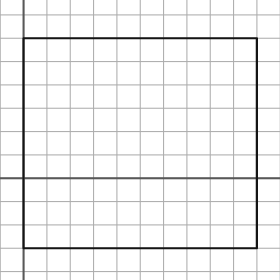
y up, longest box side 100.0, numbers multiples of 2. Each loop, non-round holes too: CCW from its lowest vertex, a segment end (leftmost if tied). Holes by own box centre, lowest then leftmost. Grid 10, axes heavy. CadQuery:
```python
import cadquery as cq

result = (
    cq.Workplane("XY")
    .moveTo(0.0, -30.0)
    .lineTo(100.0, -30.0)
    .lineTo(100.0, 60.0)
    .lineTo(0.0, 60.0)
    .close()
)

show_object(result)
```